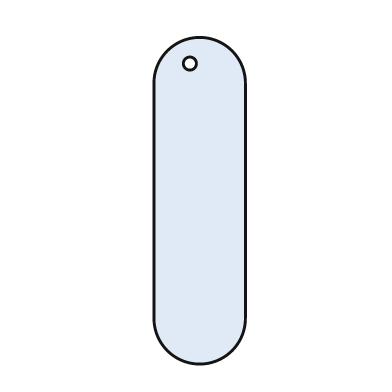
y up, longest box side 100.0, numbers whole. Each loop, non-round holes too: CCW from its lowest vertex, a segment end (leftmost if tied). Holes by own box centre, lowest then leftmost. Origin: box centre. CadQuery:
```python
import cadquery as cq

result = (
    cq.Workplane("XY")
    .moveTo(-14.0, -36.0)
    .threePointArc((0.0, -50.0), (14.0, -36.0))
    .lineTo(14.0, 36.0)
    .threePointArc((0.0, 50.0), (-14.0, 36.0))
    .close()
    .moveTo(-3.0, 42.0)
    .circle(2.0)
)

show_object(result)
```